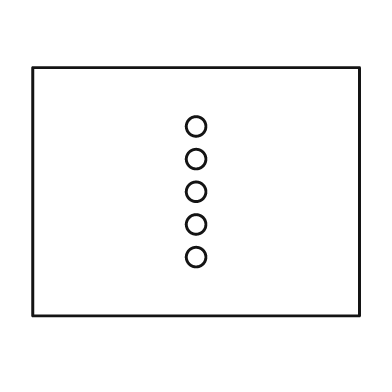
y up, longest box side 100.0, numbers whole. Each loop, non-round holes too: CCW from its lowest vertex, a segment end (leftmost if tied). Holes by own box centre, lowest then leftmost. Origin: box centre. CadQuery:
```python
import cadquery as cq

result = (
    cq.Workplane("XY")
    .moveTo(-50.0, -38.0)
    .lineTo(50.0, -38.0)
    .lineTo(50.0, 38.0)
    .lineTo(-50.0, 38.0)
    .close()
    .moveTo(0.0, -20.0)
    .circle(3.0)
    .moveTo(0.0, -10.0)
    .circle(3.0)
    .moveTo(0.0, 0.0)
    .circle(3.0)
    .moveTo(0.0, 10.0)
    .circle(3.0)
    .moveTo(0.0, 20.0)
    .circle(3.0)
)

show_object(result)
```